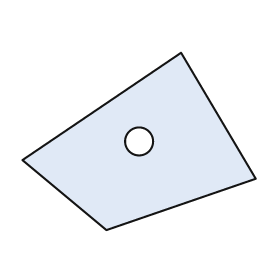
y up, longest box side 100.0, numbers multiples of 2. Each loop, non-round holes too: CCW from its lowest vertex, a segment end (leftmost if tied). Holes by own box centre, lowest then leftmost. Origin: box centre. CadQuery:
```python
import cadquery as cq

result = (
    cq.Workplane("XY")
    .moveTo(-14.0, -38.0)
    .lineTo(50.0, -16.0)
    .lineTo(18.0, 38.0)
    .lineTo(-50.0, -8.0)
    .close()
    .moveTo(0.0, 0.0)
    .circle(6.0)
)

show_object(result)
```